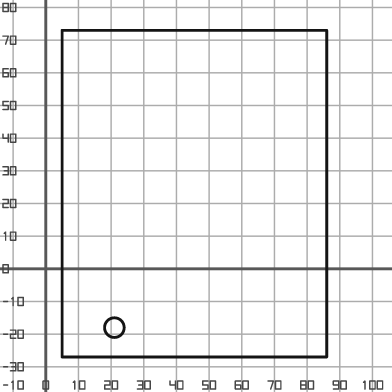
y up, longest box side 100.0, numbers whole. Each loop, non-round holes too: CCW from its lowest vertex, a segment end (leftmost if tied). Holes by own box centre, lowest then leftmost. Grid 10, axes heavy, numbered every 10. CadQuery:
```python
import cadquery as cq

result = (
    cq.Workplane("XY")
    .moveTo(5.0, -27.0)
    .lineTo(86.0, -27.0)
    .lineTo(86.0, 73.0)
    .lineTo(5.0, 73.0)
    .close()
    .moveTo(21.0, -18.0)
    .circle(3.0)
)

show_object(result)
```